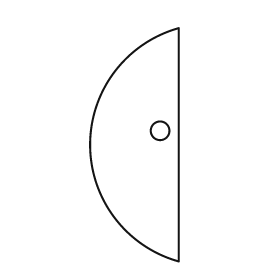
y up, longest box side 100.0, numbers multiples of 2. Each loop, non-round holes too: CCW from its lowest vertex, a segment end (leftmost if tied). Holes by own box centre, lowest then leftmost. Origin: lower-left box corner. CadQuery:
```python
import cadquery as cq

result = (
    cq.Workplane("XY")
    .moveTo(38.0, 0.0)
    .lineTo(38.0, 100.0)
    .threePointArc((0.0, 50.0), (38.0, 0.0))
    .close()
    .moveTo(30.0, 56.0)
    .circle(4.0)
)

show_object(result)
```